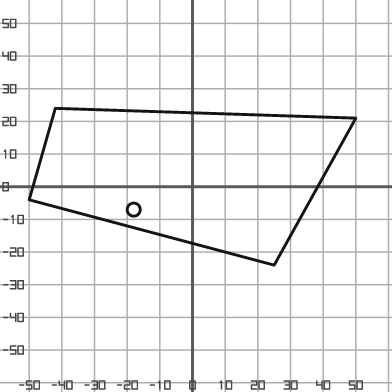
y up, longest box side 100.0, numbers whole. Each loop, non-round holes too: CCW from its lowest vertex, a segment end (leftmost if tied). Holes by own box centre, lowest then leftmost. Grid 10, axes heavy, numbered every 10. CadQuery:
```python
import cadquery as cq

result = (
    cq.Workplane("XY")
    .moveTo(25.0, -24.0)
    .lineTo(50.0, 21.0)
    .lineTo(-42.0, 24.0)
    .lineTo(-50.0, -4.0)
    .close()
    .moveTo(-18.0, -7.0)
    .circle(2.0)
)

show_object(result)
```